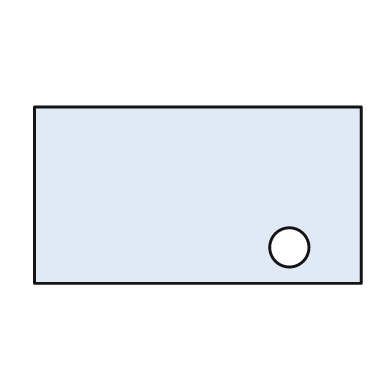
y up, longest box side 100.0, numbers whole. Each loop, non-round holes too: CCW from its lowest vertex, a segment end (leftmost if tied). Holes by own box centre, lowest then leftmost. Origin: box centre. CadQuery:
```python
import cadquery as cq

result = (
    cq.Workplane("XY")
    .moveTo(-50.0, -27.0)
    .lineTo(50.0, -27.0)
    .lineTo(50.0, 27.0)
    .lineTo(-50.0, 27.0)
    .close()
    .moveTo(28.0, -16.0)
    .circle(6.0)
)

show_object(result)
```